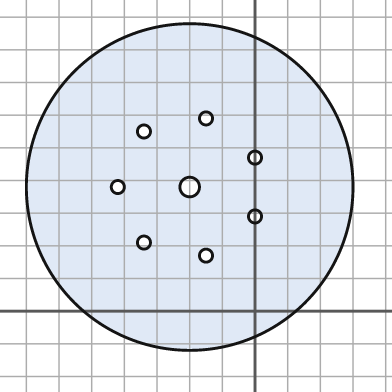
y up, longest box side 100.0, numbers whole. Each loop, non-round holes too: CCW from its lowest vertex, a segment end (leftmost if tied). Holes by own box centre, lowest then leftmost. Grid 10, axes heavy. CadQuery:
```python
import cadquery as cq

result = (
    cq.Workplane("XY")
    .moveTo(-20.0, 38.0)
    .circle(50.0)
    .moveTo(-15.0, 17.0)
    .circle(2.0)
    .moveTo(-34.0, 21.0)
    .circle(2.0)
    .moveTo(0.0, 29.0)
    .circle(2.0)
    .moveTo(-42.0, 38.0)
    .circle(2.0)
    .moveTo(-20.0, 38.0)
    .circle(3.0)
    .moveTo(0.0, 47.0)
    .circle(2.0)
    .moveTo(-34.0, 55.0)
    .circle(2.0)
    .moveTo(-15.0, 59.0)
    .circle(2.0)
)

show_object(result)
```